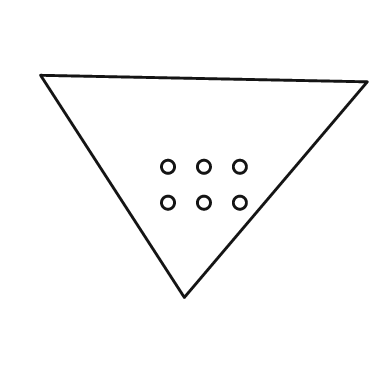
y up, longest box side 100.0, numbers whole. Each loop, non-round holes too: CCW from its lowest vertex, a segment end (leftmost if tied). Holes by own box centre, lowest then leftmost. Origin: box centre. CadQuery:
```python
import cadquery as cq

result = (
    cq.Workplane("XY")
    .moveTo(-6.0, -34.0)
    .lineTo(50.0, 32.0)
    .lineTo(-50.0, 34.0)
    .close()
    .moveTo(-11.0, -5.0)
    .circle(2.0)
    .moveTo(0.0, -5.0)
    .circle(2.0)
    .moveTo(11.0, -5.0)
    .circle(2.0)
    .moveTo(-11.0, 6.0)
    .circle(2.0)
    .moveTo(0.0, 6.0)
    .circle(2.0)
    .moveTo(11.0, 6.0)
    .circle(2.0)
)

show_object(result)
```